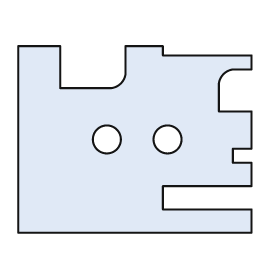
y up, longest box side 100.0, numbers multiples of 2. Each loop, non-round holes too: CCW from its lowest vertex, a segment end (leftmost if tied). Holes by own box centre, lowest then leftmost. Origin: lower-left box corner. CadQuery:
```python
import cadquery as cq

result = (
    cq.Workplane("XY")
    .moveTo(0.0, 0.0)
    .lineTo(100.0, 0.0)
    .lineTo(100.0, 10.0)
    .lineTo(62.0, 10.0)
    .lineTo(62.0, 20.0)
    .lineTo(100.0, 20.0)
    .lineTo(100.0, 30.0)
    .lineTo(92.0, 30.0)
    .lineTo(92.0, 36.0)
    .lineTo(100.0, 36.0)
    .lineTo(100.0, 52.0)
    .lineTo(86.0, 52.0)
    .lineTo(86.0, 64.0)
    .threePointArc((88.0, 68.0), (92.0, 70.0))
    .lineTo(100.0, 70.0)
    .lineTo(100.0, 76.0)
    .lineTo(62.0, 76.0)
    .lineTo(62.0, 80.0)
    .lineTo(46.0, 80.0)
    .lineTo(46.0, 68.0)
    .threePointArc((44.0, 64.0), (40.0, 62.0))
    .lineTo(18.0, 62.0)
    .lineTo(18.0, 80.0)
    .lineTo(0.0, 80.0)
    .close()
    .moveTo(38.0, 40.0)
    .circle(6.0)
    .moveTo(64.0, 40.0)
    .circle(6.0)
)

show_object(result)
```